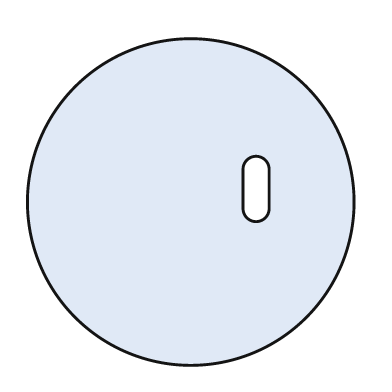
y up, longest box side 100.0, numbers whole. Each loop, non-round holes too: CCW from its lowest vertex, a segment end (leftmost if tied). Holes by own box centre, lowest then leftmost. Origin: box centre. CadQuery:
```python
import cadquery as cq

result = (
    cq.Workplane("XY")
    .moveTo(0.0, 0.0)
    .circle(50.0)
    .moveTo(16.0, -2.0)
    .threePointArc((20.0, -6.0), (24.0, -2.0))
    .lineTo(24.0, 10.0)
    .threePointArc((20.0, 14.0), (16.0, 10.0))
    .close()
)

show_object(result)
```